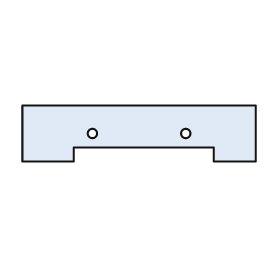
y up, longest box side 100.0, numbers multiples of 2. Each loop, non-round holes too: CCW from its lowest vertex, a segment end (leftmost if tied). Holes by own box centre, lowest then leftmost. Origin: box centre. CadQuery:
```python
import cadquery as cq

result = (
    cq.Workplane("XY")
    .moveTo(-50.0, -12.0)
    .lineTo(-28.0, -12.0)
    .lineTo(-28.0, -6.0)
    .lineTo(32.0, -6.0)
    .lineTo(32.0, -12.0)
    .lineTo(50.0, -12.0)
    .lineTo(50.0, 12.0)
    .lineTo(-50.0, 12.0)
    .close()
    .moveTo(-20.0, 0.0)
    .circle(2.0)
    .moveTo(20.0, 0.0)
    .circle(2.0)
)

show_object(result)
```